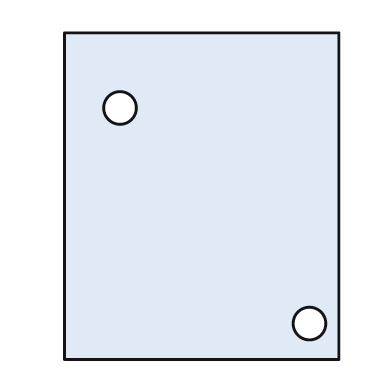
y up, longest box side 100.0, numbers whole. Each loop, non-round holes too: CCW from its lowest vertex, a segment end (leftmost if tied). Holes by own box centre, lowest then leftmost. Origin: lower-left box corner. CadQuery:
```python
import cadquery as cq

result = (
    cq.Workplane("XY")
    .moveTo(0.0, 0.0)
    .lineTo(84.0, 0.0)
    .lineTo(84.0, 100.0)
    .lineTo(0.0, 100.0)
    .close()
    .moveTo(75.0, 11.0)
    .circle(5.0)
    .moveTo(17.0, 77.0)
    .circle(5.0)
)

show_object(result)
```